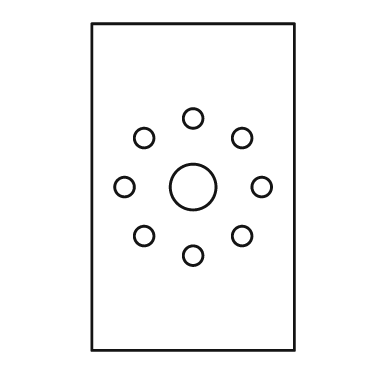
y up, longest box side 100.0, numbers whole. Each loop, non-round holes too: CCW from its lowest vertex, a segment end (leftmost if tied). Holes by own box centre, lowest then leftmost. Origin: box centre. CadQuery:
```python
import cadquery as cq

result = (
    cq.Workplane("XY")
    .moveTo(-31.0, -50.0)
    .lineTo(31.0, -50.0)
    .lineTo(31.0, 50.0)
    .lineTo(-31.0, 50.0)
    .close()
    .moveTo(0.0, -21.0)
    .circle(3.0)
    .moveTo(-15.0, -15.0)
    .circle(3.0)
    .moveTo(15.0, -15.0)
    .circle(3.0)
    .moveTo(-21.0, 0.0)
    .circle(3.0)
    .moveTo(0.0, 0.0)
    .circle(7.0)
    .moveTo(21.0, 0.0)
    .circle(3.0)
    .moveTo(-15.0, 15.0)
    .circle(3.0)
    .moveTo(15.0, 15.0)
    .circle(3.0)
    .moveTo(0.0, 21.0)
    .circle(3.0)
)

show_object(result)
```